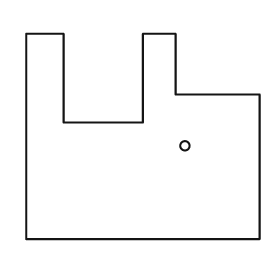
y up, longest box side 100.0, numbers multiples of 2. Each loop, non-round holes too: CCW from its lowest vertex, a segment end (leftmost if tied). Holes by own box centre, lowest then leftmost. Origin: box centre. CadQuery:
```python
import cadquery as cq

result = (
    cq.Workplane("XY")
    .moveTo(-50.0, -44.0)
    .lineTo(50.0, -44.0)
    .lineTo(50.0, 18.0)
    .lineTo(14.0, 18.0)
    .lineTo(14.0, 44.0)
    .lineTo(0.0, 44.0)
    .lineTo(0.0, 6.0)
    .lineTo(-34.0, 6.0)
    .lineTo(-34.0, 44.0)
    .lineTo(-50.0, 44.0)
    .close()
    .moveTo(18.0, -4.0)
    .circle(2.0)
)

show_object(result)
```